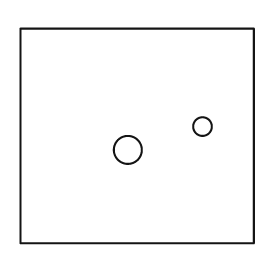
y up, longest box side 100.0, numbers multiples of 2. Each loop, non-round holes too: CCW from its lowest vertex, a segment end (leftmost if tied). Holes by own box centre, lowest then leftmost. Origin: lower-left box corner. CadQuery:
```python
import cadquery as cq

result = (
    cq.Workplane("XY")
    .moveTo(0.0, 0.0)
    .lineTo(100.0, 0.0)
    .lineTo(100.0, 92.0)
    .lineTo(0.0, 92.0)
    .close()
    .moveTo(46.0, 40.0)
    .circle(6.0)
    .moveTo(78.0, 50.0)
    .circle(4.0)
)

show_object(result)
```